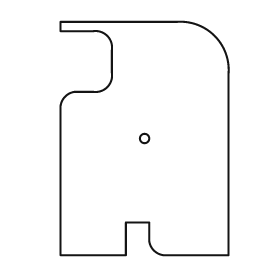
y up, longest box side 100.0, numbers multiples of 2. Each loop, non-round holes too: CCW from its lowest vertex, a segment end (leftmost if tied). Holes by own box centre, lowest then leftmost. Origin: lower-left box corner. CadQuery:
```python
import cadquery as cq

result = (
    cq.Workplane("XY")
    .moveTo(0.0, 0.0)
    .lineTo(28.0, 0.0)
    .lineTo(28.0, 14.0)
    .lineTo(38.0, 14.0)
    .lineTo(38.0, 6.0)
    .threePointArc((40.0, 2.0), (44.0, 0.0))
    .lineTo(72.0, 0.0)
    .lineTo(72.0, 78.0)
    .threePointArc((66.0, 94.0), (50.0, 100.0))
    .lineTo(0.0, 100.0)
    .lineTo(0.0, 96.0)
    .lineTo(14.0, 96.0)
    .threePointArc((20.0, 94.0), (22.0, 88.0))
    .lineTo(22.0, 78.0)
    .threePointArc((20.0, 72.0), (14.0, 70.0))
    .lineTo(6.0, 70.0)
    .threePointArc((2.0, 68.0), (0.0, 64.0))
    .close()
    .moveTo(36.0, 50.0)
    .circle(2.0)
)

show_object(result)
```